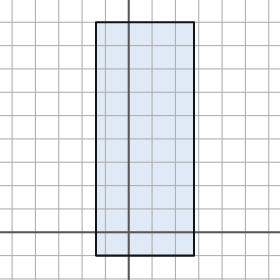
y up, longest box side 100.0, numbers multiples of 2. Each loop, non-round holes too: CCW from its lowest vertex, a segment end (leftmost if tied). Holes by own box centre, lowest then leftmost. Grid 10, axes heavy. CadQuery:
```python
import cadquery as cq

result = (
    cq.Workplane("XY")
    .moveTo(-14.0, -10.0)
    .lineTo(28.0, -10.0)
    .lineTo(28.0, 90.0)
    .lineTo(-14.0, 90.0)
    .close()
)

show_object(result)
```